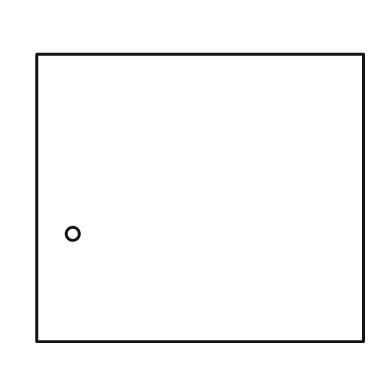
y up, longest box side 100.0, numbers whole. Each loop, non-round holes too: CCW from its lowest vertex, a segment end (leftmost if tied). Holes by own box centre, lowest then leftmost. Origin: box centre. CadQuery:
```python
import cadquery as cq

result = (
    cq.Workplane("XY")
    .moveTo(-50.0, -44.0)
    .lineTo(50.0, -44.0)
    .lineTo(50.0, 44.0)
    .lineTo(-50.0, 44.0)
    .close()
    .moveTo(-39.0, -11.0)
    .circle(2.0)
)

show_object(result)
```